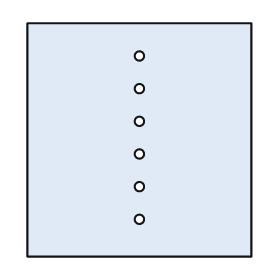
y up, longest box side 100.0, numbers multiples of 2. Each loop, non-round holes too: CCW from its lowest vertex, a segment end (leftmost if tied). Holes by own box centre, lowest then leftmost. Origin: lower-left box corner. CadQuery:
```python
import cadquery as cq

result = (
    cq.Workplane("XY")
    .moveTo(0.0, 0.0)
    .lineTo(96.0, 0.0)
    .lineTo(96.0, 100.0)
    .lineTo(0.0, 100.0)
    .close()
    .moveTo(48.0, 16.0)
    .circle(2.0)
    .moveTo(48.0, 30.0)
    .circle(2.0)
    .moveTo(48.0, 44.0)
    .circle(2.0)
    .moveTo(48.0, 58.0)
    .circle(2.0)
    .moveTo(48.0, 72.0)
    .circle(2.0)
    .moveTo(48.0, 86.0)
    .circle(2.0)
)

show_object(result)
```